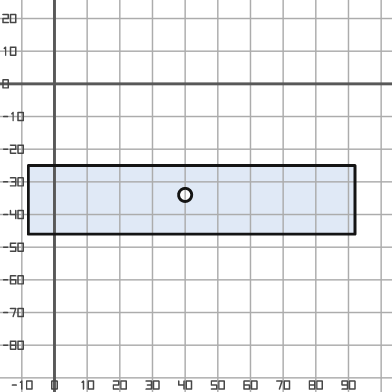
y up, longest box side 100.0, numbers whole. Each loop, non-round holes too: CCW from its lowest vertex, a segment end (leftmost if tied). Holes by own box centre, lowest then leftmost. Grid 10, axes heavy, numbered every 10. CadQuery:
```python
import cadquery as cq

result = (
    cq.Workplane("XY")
    .moveTo(-8.0, -46.0)
    .lineTo(92.0, -46.0)
    .lineTo(92.0, -25.0)
    .lineTo(-8.0, -25.0)
    .close()
    .moveTo(40.0, -34.0)
    .circle(2.0)
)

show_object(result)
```